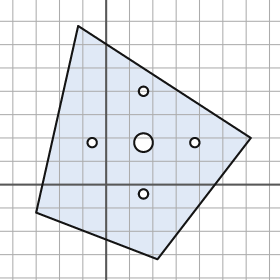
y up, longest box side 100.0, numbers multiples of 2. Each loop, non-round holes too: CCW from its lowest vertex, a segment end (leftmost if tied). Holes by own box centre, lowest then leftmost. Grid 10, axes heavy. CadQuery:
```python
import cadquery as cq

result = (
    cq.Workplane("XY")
    .moveTo(22.0, -32.0)
    .lineTo(62.0, 20.0)
    .lineTo(-12.0, 68.0)
    .lineTo(-30.0, -12.0)
    .close()
    .moveTo(16.0, -4.0)
    .circle(2.0)
    .moveTo(-6.0, 18.0)
    .circle(2.0)
    .moveTo(16.0, 18.0)
    .circle(4.0)
    .moveTo(38.0, 18.0)
    .circle(2.0)
    .moveTo(16.0, 40.0)
    .circle(2.0)
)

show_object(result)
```